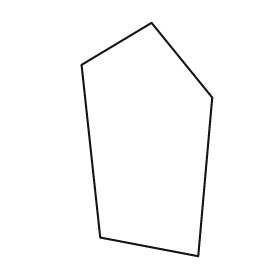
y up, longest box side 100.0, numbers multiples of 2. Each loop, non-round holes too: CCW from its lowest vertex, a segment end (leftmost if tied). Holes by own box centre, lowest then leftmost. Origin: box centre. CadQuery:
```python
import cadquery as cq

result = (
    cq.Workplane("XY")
    .moveTo(22.0, -50.0)
    .lineTo(28.0, 18.0)
    .lineTo(2.0, 50.0)
    .lineTo(-28.0, 32.0)
    .lineTo(-20.0, -42.0)
    .close()
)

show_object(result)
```